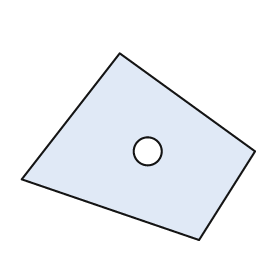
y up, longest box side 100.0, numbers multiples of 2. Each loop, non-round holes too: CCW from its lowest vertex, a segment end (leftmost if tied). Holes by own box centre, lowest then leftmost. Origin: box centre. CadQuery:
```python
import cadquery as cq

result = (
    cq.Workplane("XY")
    .moveTo(26.0, -40.0)
    .lineTo(50.0, -2.0)
    .lineTo(-8.0, 40.0)
    .lineTo(-50.0, -14.0)
    .close()
    .moveTo(4.0, -2.0)
    .circle(6.0)
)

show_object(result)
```